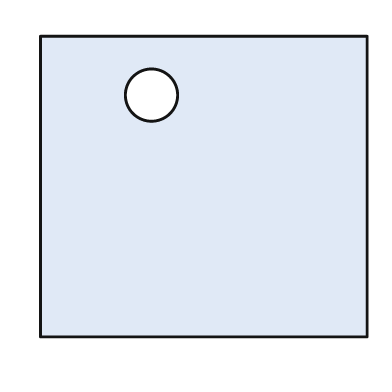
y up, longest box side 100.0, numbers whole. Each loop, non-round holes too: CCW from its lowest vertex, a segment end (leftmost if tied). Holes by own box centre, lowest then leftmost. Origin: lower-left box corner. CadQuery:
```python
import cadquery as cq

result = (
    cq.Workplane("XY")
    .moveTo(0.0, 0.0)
    .lineTo(100.0, 0.0)
    .lineTo(100.0, 92.0)
    .lineTo(0.0, 92.0)
    .close()
    .moveTo(34.0, 74.0)
    .circle(8.0)
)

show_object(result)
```